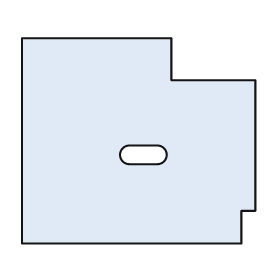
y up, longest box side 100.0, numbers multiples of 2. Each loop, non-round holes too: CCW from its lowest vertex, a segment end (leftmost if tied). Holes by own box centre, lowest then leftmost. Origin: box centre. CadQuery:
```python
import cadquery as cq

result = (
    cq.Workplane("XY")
    .moveTo(-50.0, -44.0)
    .lineTo(44.0, -44.0)
    .lineTo(44.0, -30.0)
    .lineTo(50.0, -30.0)
    .lineTo(50.0, 26.0)
    .lineTo(14.0, 26.0)
    .lineTo(14.0, 44.0)
    .lineTo(-50.0, 44.0)
    .close()
    .moveTo(-4.0, -10.0)
    .lineTo(8.0, -10.0)
    .threePointArc((12.0, -6.0), (8.0, -2.0))
    .lineTo(-4.0, -2.0)
    .threePointArc((-8.0, -6.0), (-4.0, -10.0))
    .close()
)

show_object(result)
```